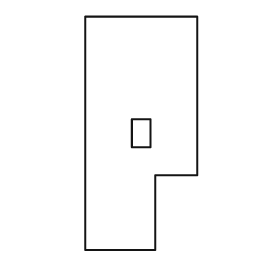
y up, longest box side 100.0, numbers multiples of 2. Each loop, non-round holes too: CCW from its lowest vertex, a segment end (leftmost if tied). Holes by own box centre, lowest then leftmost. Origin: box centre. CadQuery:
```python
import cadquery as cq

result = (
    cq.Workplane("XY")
    .moveTo(-24.0, -50.0)
    .lineTo(6.0, -50.0)
    .lineTo(6.0, -18.0)
    .lineTo(24.0, -18.0)
    .lineTo(24.0, 50.0)
    .lineTo(-24.0, 50.0)
    .close()
    .moveTo(-4.0, -6.0)
    .lineTo(4.0, -6.0)
    .lineTo(4.0, 6.0)
    .lineTo(-4.0, 6.0)
    .close()
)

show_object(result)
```